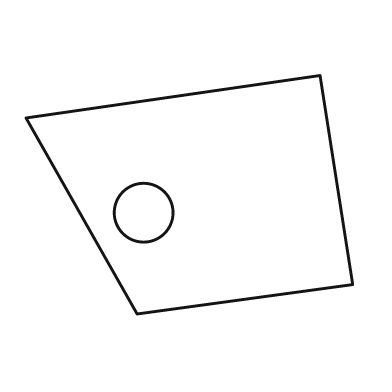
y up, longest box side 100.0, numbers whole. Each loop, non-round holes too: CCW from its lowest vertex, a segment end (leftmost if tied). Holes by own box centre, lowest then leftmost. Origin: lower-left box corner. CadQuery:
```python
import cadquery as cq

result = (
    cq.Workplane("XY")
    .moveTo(34.0, 0.0)
    .lineTo(100.0, 9.0)
    .lineTo(90.0, 73.0)
    .lineTo(0.0, 60.0)
    .close()
    .moveTo(36.0, 31.0)
    .circle(9.0)
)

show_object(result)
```